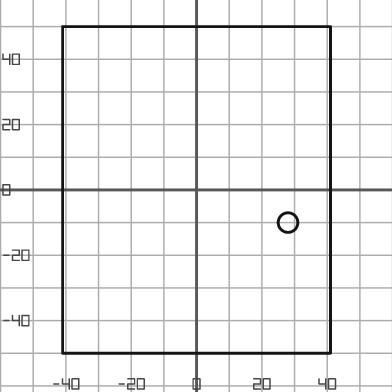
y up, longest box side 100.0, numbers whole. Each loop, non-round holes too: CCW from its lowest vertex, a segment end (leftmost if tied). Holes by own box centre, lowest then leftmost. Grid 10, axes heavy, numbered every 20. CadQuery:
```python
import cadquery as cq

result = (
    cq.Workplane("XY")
    .moveTo(-41.0, -50.0)
    .lineTo(41.0, -50.0)
    .lineTo(41.0, 50.0)
    .lineTo(-41.0, 50.0)
    .close()
    .moveTo(28.0, -10.0)
    .circle(3.0)
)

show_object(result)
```